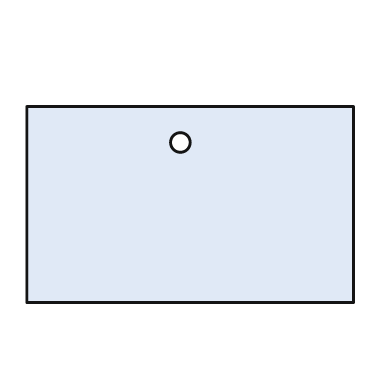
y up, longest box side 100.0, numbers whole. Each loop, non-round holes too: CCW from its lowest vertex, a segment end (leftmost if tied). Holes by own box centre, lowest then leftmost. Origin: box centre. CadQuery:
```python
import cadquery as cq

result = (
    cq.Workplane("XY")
    .moveTo(-50.0, -30.0)
    .lineTo(50.0, -30.0)
    .lineTo(50.0, 30.0)
    .lineTo(-50.0, 30.0)
    .close()
    .moveTo(-3.0, 19.0)
    .circle(3.0)
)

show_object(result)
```